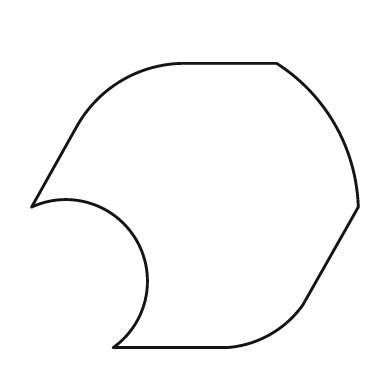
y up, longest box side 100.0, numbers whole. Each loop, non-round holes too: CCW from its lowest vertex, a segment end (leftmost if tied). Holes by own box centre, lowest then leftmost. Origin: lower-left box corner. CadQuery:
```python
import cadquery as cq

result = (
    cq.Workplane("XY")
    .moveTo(25.0, 0.0)
    .lineTo(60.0, 0.0)
    .threePointArc((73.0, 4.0), (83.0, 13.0))
    .lineTo(100.0, 43.0)
    .threePointArc((93.0, 68.0), (75.0, 87.0))
    .lineTo(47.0, 87.0)
    .threePointArc((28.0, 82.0), (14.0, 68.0))
    .lineTo(0.0, 43.0)
    .threePointArc((32.0, 33.0), (25.0, 0.0))
    .close()
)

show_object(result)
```